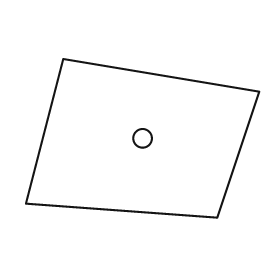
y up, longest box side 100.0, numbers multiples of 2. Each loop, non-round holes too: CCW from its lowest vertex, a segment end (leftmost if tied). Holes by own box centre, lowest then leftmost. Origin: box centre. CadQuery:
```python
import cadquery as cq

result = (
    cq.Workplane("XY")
    .moveTo(32.0, -34.0)
    .lineTo(50.0, 20.0)
    .lineTo(-34.0, 34.0)
    .lineTo(-50.0, -28.0)
    .close()
    .moveTo(0.0, 0.0)
    .circle(4.0)
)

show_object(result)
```